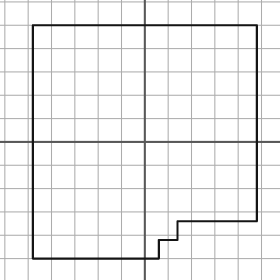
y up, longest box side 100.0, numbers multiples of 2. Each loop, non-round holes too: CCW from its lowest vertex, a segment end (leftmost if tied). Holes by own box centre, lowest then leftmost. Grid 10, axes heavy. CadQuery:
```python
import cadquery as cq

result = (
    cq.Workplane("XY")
    .moveTo(-48.0, -50.0)
    .lineTo(6.0, -50.0)
    .lineTo(6.0, -42.0)
    .lineTo(14.0, -42.0)
    .lineTo(14.0, -34.0)
    .lineTo(48.0, -34.0)
    .lineTo(48.0, 50.0)
    .lineTo(-48.0, 50.0)
    .close()
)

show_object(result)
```